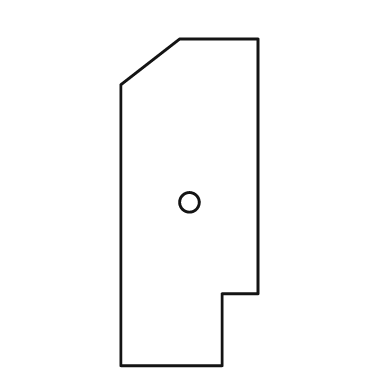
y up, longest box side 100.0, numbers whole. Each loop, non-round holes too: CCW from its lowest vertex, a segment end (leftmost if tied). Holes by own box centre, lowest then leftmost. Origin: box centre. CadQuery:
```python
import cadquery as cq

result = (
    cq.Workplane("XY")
    .moveTo(-21.0, -50.0)
    .lineTo(10.0, -50.0)
    .lineTo(10.0, -28.0)
    .lineTo(21.0, -28.0)
    .lineTo(21.0, 50.0)
    .lineTo(-3.0, 50.0)
    .lineTo(-21.0, 36.0)
    .close()
    .moveTo(0.0, 0.0)
    .circle(3.0)
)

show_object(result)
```